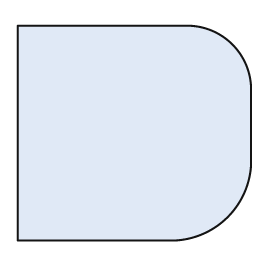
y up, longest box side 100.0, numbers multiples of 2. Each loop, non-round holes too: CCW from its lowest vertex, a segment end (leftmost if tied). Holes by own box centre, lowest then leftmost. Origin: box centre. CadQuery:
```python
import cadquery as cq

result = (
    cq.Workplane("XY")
    .moveTo(-50.0, -46.0)
    .lineTo(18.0, -46.0)
    .threePointArc((40.0, -36.0), (50.0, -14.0))
    .lineTo(50.0, 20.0)
    .threePointArc((42.0, 38.0), (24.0, 46.0))
    .lineTo(-50.0, 46.0)
    .close()
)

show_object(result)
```